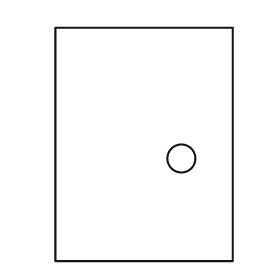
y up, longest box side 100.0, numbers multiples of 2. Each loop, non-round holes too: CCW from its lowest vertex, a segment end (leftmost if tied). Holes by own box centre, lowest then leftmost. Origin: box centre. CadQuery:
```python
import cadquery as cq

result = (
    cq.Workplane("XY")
    .moveTo(-38.0, -50.0)
    .lineTo(38.0, -50.0)
    .lineTo(38.0, 50.0)
    .lineTo(-38.0, 50.0)
    .close()
    .moveTo(16.0, -6.0)
    .circle(6.0)
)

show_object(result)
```